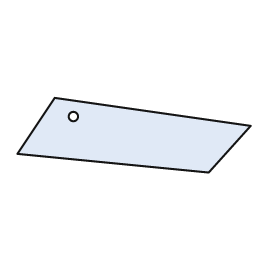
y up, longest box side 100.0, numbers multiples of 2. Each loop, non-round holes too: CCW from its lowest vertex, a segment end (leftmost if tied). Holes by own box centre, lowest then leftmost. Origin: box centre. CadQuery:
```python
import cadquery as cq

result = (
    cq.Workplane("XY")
    .moveTo(32.0, -16.0)
    .lineTo(50.0, 4.0)
    .lineTo(-34.0, 16.0)
    .lineTo(-50.0, -8.0)
    .close()
    .moveTo(-26.0, 8.0)
    .circle(2.0)
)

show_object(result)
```